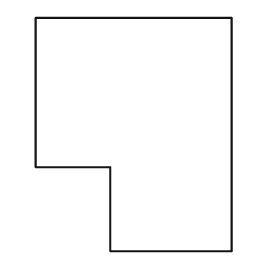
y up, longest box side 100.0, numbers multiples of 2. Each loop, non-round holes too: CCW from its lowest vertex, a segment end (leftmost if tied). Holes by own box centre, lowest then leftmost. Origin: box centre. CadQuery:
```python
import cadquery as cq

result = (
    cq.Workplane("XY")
    .moveTo(-10.0, -50.0)
    .lineTo(42.0, -50.0)
    .lineTo(42.0, 50.0)
    .lineTo(-42.0, 50.0)
    .lineTo(-42.0, -14.0)
    .lineTo(-10.0, -14.0)
    .close()
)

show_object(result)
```